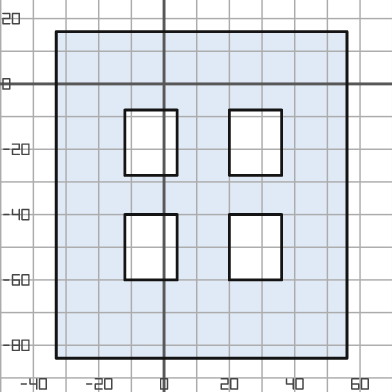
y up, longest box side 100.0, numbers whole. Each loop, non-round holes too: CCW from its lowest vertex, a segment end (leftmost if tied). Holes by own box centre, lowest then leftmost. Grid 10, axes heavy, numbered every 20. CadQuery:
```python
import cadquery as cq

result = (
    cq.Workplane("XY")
    .moveTo(-33.0, -84.0)
    .lineTo(56.0, -84.0)
    .lineTo(56.0, 16.0)
    .lineTo(-33.0, 16.0)
    .close()
    .moveTo(-12.0, -60.0)
    .lineTo(4.0, -60.0)
    .lineTo(4.0, -40.0)
    .lineTo(-12.0, -40.0)
    .close()
    .moveTo(20.0, -60.0)
    .lineTo(36.0, -60.0)
    .lineTo(36.0, -40.0)
    .lineTo(20.0, -40.0)
    .close()
    .moveTo(-12.0, -28.0)
    .lineTo(4.0, -28.0)
    .lineTo(4.0, -8.0)
    .lineTo(-12.0, -8.0)
    .close()
    .moveTo(20.0, -28.0)
    .lineTo(36.0, -28.0)
    .lineTo(36.0, -8.0)
    .lineTo(20.0, -8.0)
    .close()
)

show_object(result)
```